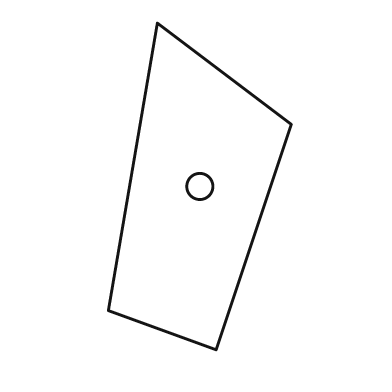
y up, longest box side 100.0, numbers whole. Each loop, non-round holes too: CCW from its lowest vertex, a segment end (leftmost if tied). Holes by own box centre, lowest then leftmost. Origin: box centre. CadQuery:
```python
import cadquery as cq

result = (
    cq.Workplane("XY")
    .moveTo(5.0, -50.0)
    .lineTo(28.0, 19.0)
    .lineTo(-13.0, 50.0)
    .lineTo(-28.0, -38.0)
    .close()
    .moveTo(0.0, 0.0)
    .circle(4.0)
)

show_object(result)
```